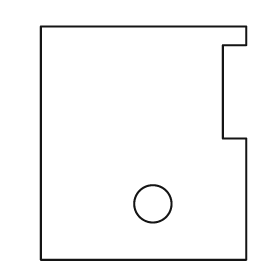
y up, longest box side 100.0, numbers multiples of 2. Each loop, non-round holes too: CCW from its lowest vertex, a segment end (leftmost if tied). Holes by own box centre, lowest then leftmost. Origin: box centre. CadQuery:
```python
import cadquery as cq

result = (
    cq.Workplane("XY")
    .moveTo(-44.0, -50.0)
    .lineTo(44.0, -50.0)
    .lineTo(44.0, 2.0)
    .lineTo(34.0, 2.0)
    .lineTo(34.0, 42.0)
    .lineTo(44.0, 42.0)
    .lineTo(44.0, 50.0)
    .lineTo(-44.0, 50.0)
    .close()
    .moveTo(4.0, -26.0)
    .circle(8.0)
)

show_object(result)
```